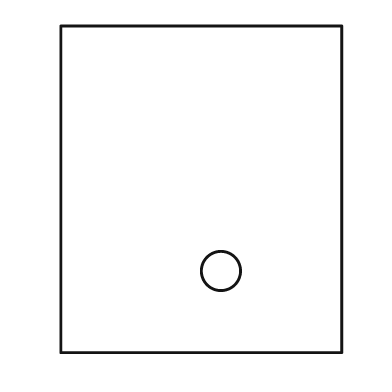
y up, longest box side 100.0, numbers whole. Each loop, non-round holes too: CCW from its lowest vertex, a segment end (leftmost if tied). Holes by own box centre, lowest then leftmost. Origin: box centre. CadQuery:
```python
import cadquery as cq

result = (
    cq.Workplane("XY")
    .moveTo(-43.0, -50.0)
    .lineTo(43.0, -50.0)
    .lineTo(43.0, 50.0)
    .lineTo(-43.0, 50.0)
    .close()
    .moveTo(6.0, -25.0)
    .circle(6.0)
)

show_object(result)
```